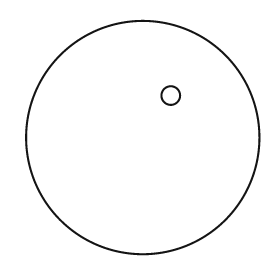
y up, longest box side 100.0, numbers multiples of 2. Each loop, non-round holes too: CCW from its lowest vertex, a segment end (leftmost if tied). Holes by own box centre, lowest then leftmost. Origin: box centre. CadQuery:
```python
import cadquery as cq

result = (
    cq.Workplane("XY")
    .moveTo(0.0, 0.0)
    .circle(50.0)
    .moveTo(12.0, 18.0)
    .circle(4.0)
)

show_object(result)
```